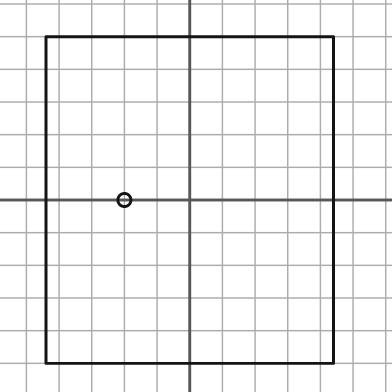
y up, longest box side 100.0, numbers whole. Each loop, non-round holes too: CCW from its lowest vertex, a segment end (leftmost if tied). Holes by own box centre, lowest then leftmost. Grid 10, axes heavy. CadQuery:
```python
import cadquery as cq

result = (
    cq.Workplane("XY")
    .moveTo(-44.0, -50.0)
    .lineTo(44.0, -50.0)
    .lineTo(44.0, 50.0)
    .lineTo(-44.0, 50.0)
    .close()
    .moveTo(-20.0, 0.0)
    .circle(2.0)
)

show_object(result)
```